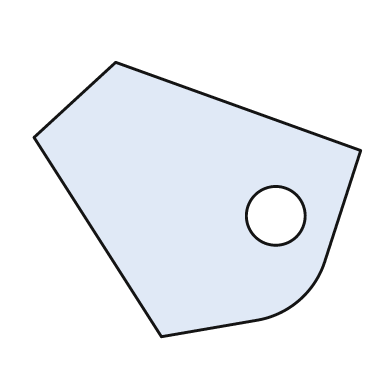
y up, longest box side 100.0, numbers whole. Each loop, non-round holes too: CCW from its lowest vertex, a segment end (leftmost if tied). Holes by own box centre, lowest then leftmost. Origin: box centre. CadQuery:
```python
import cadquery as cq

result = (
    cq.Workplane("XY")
    .moveTo(-11.0, -42.0)
    .lineTo(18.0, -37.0)
    .threePointArc((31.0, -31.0), (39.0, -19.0))
    .lineTo(50.0, 15.0)
    .lineTo(-25.0, 42.0)
    .lineTo(-50.0, 19.0)
    .close()
    .moveTo(24.0, -5.0)
    .circle(9.0)
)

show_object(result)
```